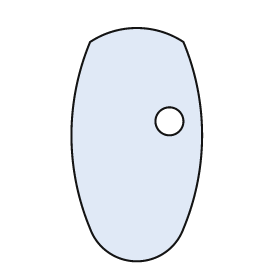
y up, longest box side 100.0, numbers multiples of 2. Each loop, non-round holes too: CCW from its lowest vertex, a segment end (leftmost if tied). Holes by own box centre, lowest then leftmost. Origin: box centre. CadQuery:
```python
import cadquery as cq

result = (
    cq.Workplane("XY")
    .moveTo(-20.0, -36.0)
    .threePointArc((0.0, -50.0), (20.0, -36.0))
    .threePointArc((28.0, 4.0), (20.0, 44.0))
    .threePointArc((0.0, 50.0), (-20.0, 44.0))
    .threePointArc((-28.0, 4.0), (-20.0, -36.0))
    .close()
    .moveTo(14.0, 10.0)
    .circle(6.0)
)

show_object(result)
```